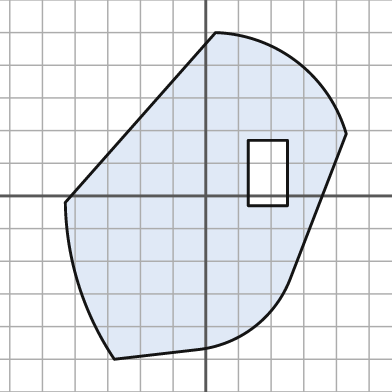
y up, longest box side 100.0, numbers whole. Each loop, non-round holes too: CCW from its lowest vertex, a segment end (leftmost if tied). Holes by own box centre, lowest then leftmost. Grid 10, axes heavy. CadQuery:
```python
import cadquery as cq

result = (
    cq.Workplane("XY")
    .moveTo(-28.0, -50.0)
    .lineTo(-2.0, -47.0)
    .threePointArc((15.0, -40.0), (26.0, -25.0))
    .lineTo(43.0, 19.0)
    .threePointArc((28.0, 41.0), (3.0, 50.0))
    .lineTo(-43.0, -2.0)
    .threePointArc((-39.0, -27.0), (-28.0, -50.0))
    .close()
    .moveTo(13.0, -3.0)
    .lineTo(25.0, -3.0)
    .lineTo(25.0, 17.0)
    .lineTo(13.0, 17.0)
    .close()
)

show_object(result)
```